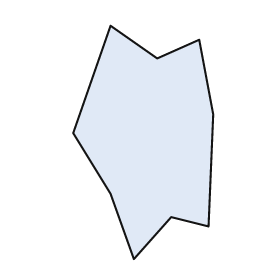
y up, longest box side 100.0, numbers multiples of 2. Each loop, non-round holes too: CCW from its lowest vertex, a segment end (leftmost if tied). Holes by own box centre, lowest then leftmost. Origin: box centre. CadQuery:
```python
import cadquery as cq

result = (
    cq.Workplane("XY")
    .moveTo(-4.0, -50.0)
    .lineTo(12.0, -32.0)
    .lineTo(28.0, -36.0)
    .lineTo(30.0, 12.0)
    .lineTo(24.0, 44.0)
    .lineTo(6.0, 36.0)
    .lineTo(-14.0, 50.0)
    .lineTo(-30.0, 4.0)
    .lineTo(-14.0, -22.0)
    .close()
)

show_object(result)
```